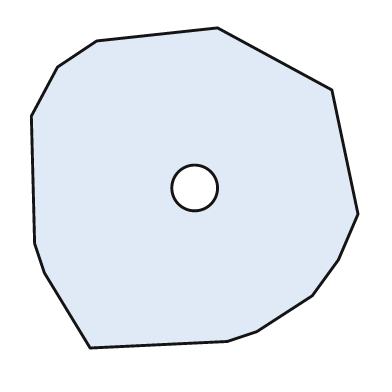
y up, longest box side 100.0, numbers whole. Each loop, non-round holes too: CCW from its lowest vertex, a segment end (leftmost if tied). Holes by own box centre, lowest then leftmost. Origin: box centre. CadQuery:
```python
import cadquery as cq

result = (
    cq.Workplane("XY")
    .moveTo(-32.0, -49.0)
    .lineTo(10.0, -47.0)
    .lineTo(19.0, -44.0)
    .lineTo(36.0, -33.0)
    .lineTo(44.0, -22.0)
    .lineTo(50.0, -8.0)
    .lineTo(42.0, 30.0)
    .lineTo(7.0, 49.0)
    .lineTo(-30.0, 45.0)
    .lineTo(-42.0, 37.0)
    .lineTo(-50.0, 22.0)
    .lineTo(-49.0, -17.0)
    .lineTo(-46.0, -26.0)
    .close()
    .moveTo(0.0, 0.0)
    .circle(7.0)
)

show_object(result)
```